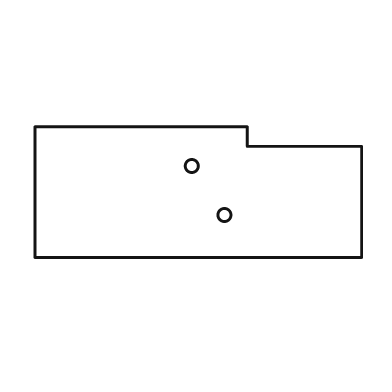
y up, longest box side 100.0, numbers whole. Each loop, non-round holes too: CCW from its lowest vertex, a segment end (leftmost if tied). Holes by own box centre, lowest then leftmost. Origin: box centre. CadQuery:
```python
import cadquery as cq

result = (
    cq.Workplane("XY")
    .moveTo(-50.0, -20.0)
    .lineTo(50.0, -20.0)
    .lineTo(50.0, 14.0)
    .lineTo(15.0, 14.0)
    .lineTo(15.0, 20.0)
    .lineTo(-50.0, 20.0)
    .close()
    .moveTo(8.0, -7.0)
    .circle(2.0)
    .moveTo(-2.0, 8.0)
    .circle(2.0)
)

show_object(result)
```